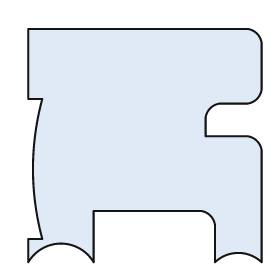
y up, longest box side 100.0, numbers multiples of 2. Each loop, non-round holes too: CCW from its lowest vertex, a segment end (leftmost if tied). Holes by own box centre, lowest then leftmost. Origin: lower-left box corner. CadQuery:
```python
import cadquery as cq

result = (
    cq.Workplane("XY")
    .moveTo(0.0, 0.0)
    .threePointArc((14.0, 8.0), (28.0, 0.0))
    .lineTo(28.0, 22.0)
    .lineTo(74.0, 22.0)
    .threePointArc((78.0, 20.0), (80.0, 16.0))
    .lineTo(80.0, 0.0)
    .threePointArc((90.0, 4.0), (100.0, 0.0))
    .lineTo(100.0, 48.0)
    .threePointArc((98.0, 52.0), (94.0, 54.0))
    .lineTo(76.0, 54.0)
    .lineTo(76.0, 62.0)
    .threePointArc((78.0, 66.0), (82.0, 68.0))
    .lineTo(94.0, 68.0)
    .threePointArc((98.0, 70.0), (100.0, 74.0))
    .lineTo(100.0, 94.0)
    .threePointArc((98.0, 98.0), (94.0, 100.0))
    .lineTo(0.0, 100.0)
    .lineTo(0.0, 70.0)
    .lineTo(6.0, 70.0)
    .threePointArc((2.0, 40.0), (6.0, 10.0))
    .lineTo(0.0, 10.0)
    .close()
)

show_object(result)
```